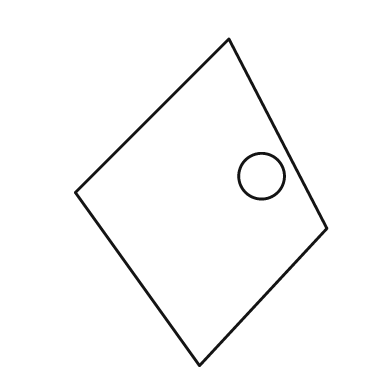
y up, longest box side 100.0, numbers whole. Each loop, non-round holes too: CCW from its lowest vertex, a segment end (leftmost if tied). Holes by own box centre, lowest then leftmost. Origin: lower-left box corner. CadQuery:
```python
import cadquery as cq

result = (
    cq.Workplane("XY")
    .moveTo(38.0, 0.0)
    .lineTo(77.0, 42.0)
    .lineTo(47.0, 100.0)
    .lineTo(0.0, 53.0)
    .close()
    .moveTo(57.0, 58.0)
    .circle(7.0)
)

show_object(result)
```